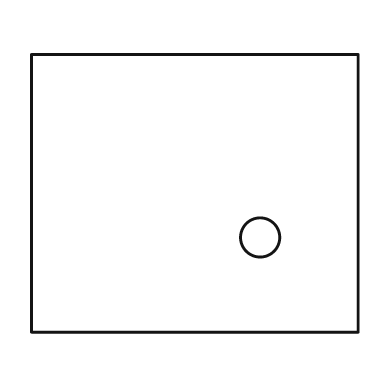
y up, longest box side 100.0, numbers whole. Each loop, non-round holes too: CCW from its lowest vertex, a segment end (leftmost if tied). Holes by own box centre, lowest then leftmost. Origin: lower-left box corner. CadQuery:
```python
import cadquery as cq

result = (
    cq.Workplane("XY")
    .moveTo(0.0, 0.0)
    .lineTo(100.0, 0.0)
    .lineTo(100.0, 85.0)
    .lineTo(0.0, 85.0)
    .close()
    .moveTo(70.0, 29.0)
    .circle(6.0)
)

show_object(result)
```